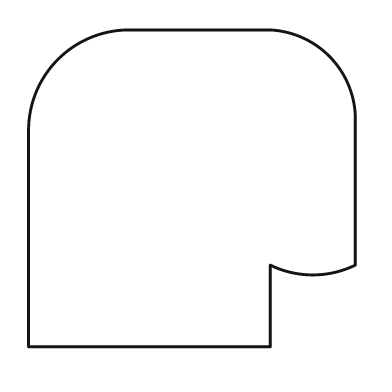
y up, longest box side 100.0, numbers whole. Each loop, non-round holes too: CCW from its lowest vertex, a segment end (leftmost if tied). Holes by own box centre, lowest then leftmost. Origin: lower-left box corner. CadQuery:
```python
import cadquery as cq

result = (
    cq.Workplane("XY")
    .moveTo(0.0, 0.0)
    .lineTo(74.0, 0.0)
    .lineTo(74.0, 25.0)
    .threePointArc((87.0, 22.0), (100.0, 25.0))
    .lineTo(100.0, 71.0)
    .threePointArc((92.0, 89.0), (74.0, 97.0))
    .lineTo(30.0, 97.0)
    .threePointArc((9.0, 88.0), (0.0, 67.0))
    .close()
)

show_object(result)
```